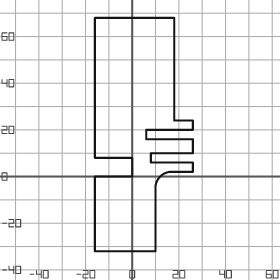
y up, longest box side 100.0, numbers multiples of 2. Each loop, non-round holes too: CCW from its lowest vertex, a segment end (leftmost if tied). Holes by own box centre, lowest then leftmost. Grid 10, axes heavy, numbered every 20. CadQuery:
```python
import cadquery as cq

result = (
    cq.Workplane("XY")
    .moveTo(-16.0, -32.0)
    .lineTo(10.0, -32.0)
    .lineTo(10.0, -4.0)
    .threePointArc((12.0, 0.0), (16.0, 2.0))
    .lineTo(26.0, 2.0)
    .lineTo(26.0, 6.0)
    .lineTo(8.0, 6.0)
    .lineTo(8.0, 10.0)
    .lineTo(26.0, 10.0)
    .lineTo(26.0, 16.0)
    .lineTo(6.0, 16.0)
    .lineTo(6.0, 20.0)
    .lineTo(26.0, 20.0)
    .lineTo(26.0, 24.0)
    .lineTo(18.0, 24.0)
    .lineTo(18.0, 68.0)
    .lineTo(-16.0, 68.0)
    .lineTo(-16.0, 8.0)
    .lineTo(0.0, 8.0)
    .lineTo(0.0, 0.0)
    .lineTo(-16.0, 0.0)
    .close()
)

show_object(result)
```